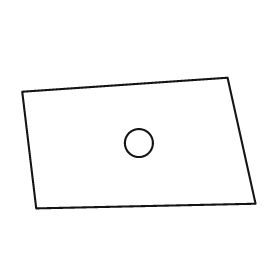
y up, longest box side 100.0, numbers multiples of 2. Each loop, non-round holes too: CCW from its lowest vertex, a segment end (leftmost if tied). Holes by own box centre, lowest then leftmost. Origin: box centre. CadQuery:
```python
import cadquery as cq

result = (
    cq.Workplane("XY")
    .moveTo(-44.0, -28.0)
    .lineTo(50.0, -26.0)
    .lineTo(38.0, 28.0)
    .lineTo(-50.0, 22.0)
    .close()
    .moveTo(0.0, 0.0)
    .circle(6.0)
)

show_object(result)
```